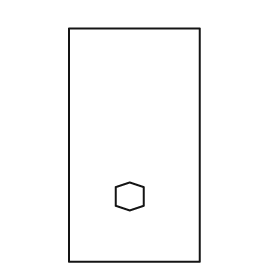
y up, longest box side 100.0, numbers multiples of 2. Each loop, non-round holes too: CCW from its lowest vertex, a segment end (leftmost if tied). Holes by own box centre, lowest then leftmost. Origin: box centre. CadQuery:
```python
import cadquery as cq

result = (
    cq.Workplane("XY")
    .moveTo(-28.0, -50.0)
    .lineTo(28.0, -50.0)
    .lineTo(28.0, 50.0)
    .lineTo(-28.0, 50.0)
    .close()
    .moveTo(-2.0, -28.0)
    .lineTo(4.0, -26.0)
    .lineTo(4.0, -18.0)
    .lineTo(-2.0, -16.0)
    .lineTo(-8.0, -18.0)
    .lineTo(-8.0, -26.0)
    .close()
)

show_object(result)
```